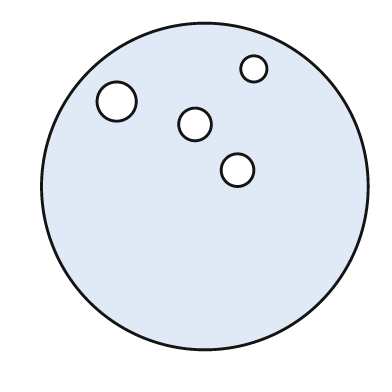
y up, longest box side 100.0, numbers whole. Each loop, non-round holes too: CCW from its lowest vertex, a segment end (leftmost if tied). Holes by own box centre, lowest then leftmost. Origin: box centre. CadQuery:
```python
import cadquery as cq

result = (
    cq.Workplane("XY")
    .moveTo(0.0, 0.0)
    .circle(50.0)
    .moveTo(10.0, 5.0)
    .circle(5.0)
    .moveTo(-3.0, 19.0)
    .circle(5.0)
    .moveTo(-27.0, 26.0)
    .circle(6.0)
    .moveTo(15.0, 36.0)
    .circle(4.0)
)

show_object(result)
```